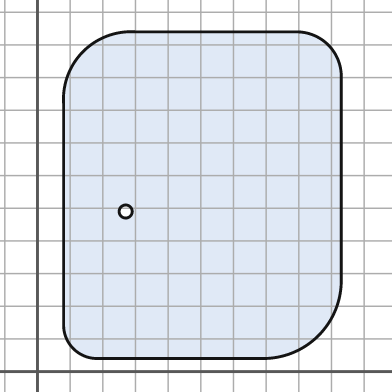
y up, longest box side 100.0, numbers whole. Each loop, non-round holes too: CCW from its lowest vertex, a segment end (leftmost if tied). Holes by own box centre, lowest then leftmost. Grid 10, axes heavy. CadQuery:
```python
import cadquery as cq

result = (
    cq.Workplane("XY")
    .moveTo(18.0, 4.0)
    .lineTo(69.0, 4.0)
    .threePointArc((86.0, 11.0), (93.0, 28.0))
    .lineTo(93.0, 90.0)
    .threePointArc((89.0, 100.0), (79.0, 104.0))
    .lineTo(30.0, 104.0)
    .threePointArc((14.0, 98.0), (8.0, 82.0))
    .lineTo(8.0, 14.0)
    .threePointArc((11.0, 7.0), (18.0, 4.0))
    .close()
    .moveTo(27.0, 49.0)
    .circle(2.0)
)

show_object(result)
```